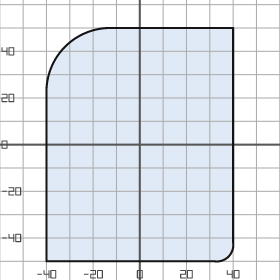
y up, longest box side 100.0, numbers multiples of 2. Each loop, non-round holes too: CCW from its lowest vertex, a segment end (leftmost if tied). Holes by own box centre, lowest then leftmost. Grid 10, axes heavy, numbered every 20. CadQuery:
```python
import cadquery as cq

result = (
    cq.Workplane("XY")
    .moveTo(-40.0, -50.0)
    .lineTo(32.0, -50.0)
    .threePointArc((38.0, -48.0), (40.0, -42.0))
    .lineTo(40.0, 50.0)
    .lineTo(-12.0, 50.0)
    .threePointArc((-32.0, 42.0), (-40.0, 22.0))
    .close()
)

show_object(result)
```